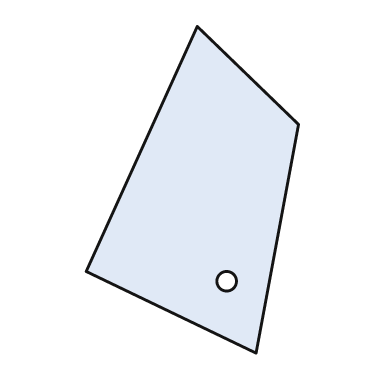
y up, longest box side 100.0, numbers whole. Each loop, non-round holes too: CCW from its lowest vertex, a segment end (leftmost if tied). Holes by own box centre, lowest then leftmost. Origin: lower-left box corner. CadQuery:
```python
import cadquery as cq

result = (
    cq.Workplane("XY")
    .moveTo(52.0, 0.0)
    .lineTo(65.0, 70.0)
    .lineTo(34.0, 100.0)
    .lineTo(0.0, 25.0)
    .close()
    .moveTo(43.0, 22.0)
    .circle(3.0)
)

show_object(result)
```